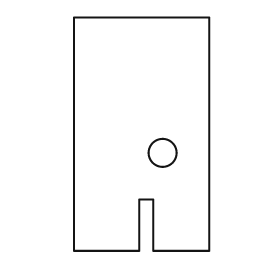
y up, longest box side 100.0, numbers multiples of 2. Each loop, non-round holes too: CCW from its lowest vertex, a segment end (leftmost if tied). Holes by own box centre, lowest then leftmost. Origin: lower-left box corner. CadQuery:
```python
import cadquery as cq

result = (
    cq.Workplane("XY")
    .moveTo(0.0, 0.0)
    .lineTo(28.0, 0.0)
    .lineTo(28.0, 22.0)
    .lineTo(34.0, 22.0)
    .lineTo(34.0, 0.0)
    .lineTo(58.0, 0.0)
    .lineTo(58.0, 100.0)
    .lineTo(0.0, 100.0)
    .close()
    .moveTo(38.0, 42.0)
    .circle(6.0)
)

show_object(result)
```